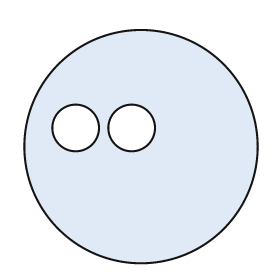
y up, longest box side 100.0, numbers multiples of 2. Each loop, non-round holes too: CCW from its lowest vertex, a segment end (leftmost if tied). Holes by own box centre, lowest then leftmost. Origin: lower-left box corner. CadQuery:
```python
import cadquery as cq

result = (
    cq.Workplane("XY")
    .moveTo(50.0, 50.0)
    .circle(50.0)
    .moveTo(22.0, 58.0)
    .circle(10.0)
    .moveTo(46.0, 58.0)
    .circle(10.0)
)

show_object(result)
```